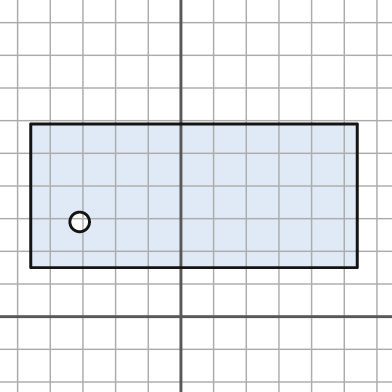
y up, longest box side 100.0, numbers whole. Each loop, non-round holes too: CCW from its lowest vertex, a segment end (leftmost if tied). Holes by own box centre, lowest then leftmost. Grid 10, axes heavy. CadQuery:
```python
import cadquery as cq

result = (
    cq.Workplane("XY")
    .moveTo(-46.0, 15.0)
    .lineTo(54.0, 15.0)
    .lineTo(54.0, 59.0)
    .lineTo(-46.0, 59.0)
    .close()
    .moveTo(-31.0, 29.0)
    .circle(3.0)
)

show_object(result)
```